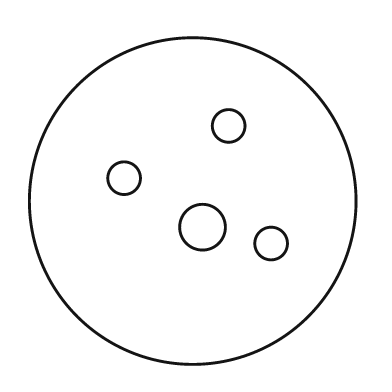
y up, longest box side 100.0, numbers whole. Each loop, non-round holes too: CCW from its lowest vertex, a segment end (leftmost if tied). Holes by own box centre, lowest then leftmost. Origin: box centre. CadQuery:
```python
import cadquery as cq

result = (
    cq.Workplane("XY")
    .moveTo(0.0, 0.0)
    .circle(50.0)
    .moveTo(24.0, -13.0)
    .circle(5.0)
    .moveTo(3.0, -8.0)
    .circle(7.0)
    .moveTo(-21.0, 7.0)
    .circle(5.0)
    .moveTo(11.0, 23.0)
    .circle(5.0)
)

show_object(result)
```